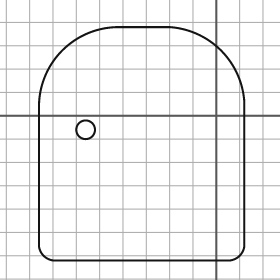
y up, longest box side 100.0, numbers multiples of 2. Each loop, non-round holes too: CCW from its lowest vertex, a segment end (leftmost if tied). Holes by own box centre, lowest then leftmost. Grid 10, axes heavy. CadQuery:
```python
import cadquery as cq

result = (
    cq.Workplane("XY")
    .moveTo(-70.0, -62.0)
    .lineTo(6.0, -62.0)
    .threePointArc((10.0, -60.0), (12.0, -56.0))
    .lineTo(12.0, 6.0)
    .threePointArc((2.0, 28.0), (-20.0, 38.0))
    .lineTo(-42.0, 38.0)
    .threePointArc((-66.0, 28.0), (-76.0, 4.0))
    .lineTo(-76.0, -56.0)
    .threePointArc((-74.0, -60.0), (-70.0, -62.0))
    .close()
    .moveTo(-56.0, -6.0)
    .circle(4.0)
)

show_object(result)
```